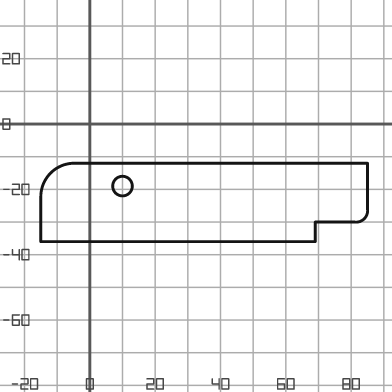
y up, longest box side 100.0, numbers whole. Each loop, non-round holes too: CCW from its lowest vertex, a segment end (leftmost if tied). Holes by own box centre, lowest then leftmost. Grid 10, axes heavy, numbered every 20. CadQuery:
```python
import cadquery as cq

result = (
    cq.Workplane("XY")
    .moveTo(-15.0, -36.0)
    .lineTo(69.0, -36.0)
    .lineTo(69.0, -30.0)
    .lineTo(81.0, -30.0)
    .threePointArc((84.0, -29.0), (85.0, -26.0))
    .lineTo(85.0, -12.0)
    .lineTo(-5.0, -12.0)
    .threePointArc((-12.0, -15.0), (-15.0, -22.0))
    .close()
    .moveTo(10.0, -19.0)
    .circle(3.0)
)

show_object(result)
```